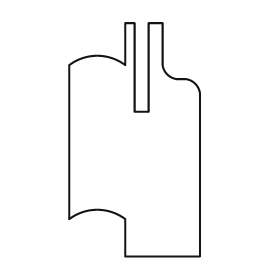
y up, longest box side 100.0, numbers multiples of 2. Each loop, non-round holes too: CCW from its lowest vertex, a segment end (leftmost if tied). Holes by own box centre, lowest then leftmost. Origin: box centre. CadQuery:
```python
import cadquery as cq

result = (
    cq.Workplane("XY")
    .moveTo(-4.0, -50.0)
    .lineTo(28.0, -50.0)
    .lineTo(28.0, 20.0)
    .threePointArc((26.0, 24.0), (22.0, 26.0))
    .lineTo(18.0, 26.0)
    .threePointArc((14.0, 28.0), (12.0, 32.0))
    .lineTo(12.0, 50.0)
    .lineTo(6.0, 50.0)
    .lineTo(6.0, 12.0)
    .lineTo(0.0, 12.0)
    .lineTo(0.0, 50.0)
    .lineTo(-4.0, 50.0)
    .lineTo(-4.0, 32.0)
    .threePointArc((-16.0, 36.0), (-28.0, 32.0))
    .lineTo(-28.0, -34.0)
    .threePointArc((-16.0, -30.0), (-4.0, -34.0))
    .close()
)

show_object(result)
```